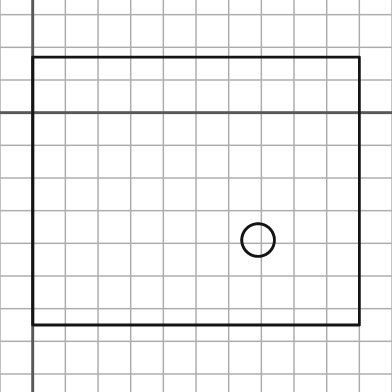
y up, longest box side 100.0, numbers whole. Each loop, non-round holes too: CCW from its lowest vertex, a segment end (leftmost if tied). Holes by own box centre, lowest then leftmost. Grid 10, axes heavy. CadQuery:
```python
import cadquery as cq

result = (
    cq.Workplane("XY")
    .moveTo(0.0, -65.0)
    .lineTo(100.0, -65.0)
    .lineTo(100.0, 17.0)
    .lineTo(0.0, 17.0)
    .close()
    .moveTo(69.0, -39.0)
    .circle(5.0)
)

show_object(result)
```